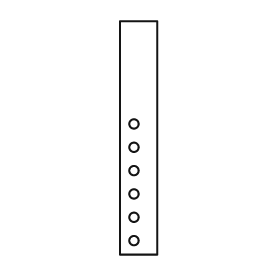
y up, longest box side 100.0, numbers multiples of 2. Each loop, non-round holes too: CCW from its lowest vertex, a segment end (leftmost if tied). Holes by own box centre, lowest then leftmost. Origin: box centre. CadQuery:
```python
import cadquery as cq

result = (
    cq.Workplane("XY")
    .moveTo(-8.0, -50.0)
    .lineTo(8.0, -50.0)
    .lineTo(8.0, 50.0)
    .lineTo(-8.0, 50.0)
    .close()
    .moveTo(-2.0, -44.0)
    .circle(2.0)
    .moveTo(-2.0, -34.0)
    .circle(2.0)
    .moveTo(-2.0, -24.0)
    .circle(2.0)
    .moveTo(-2.0, -14.0)
    .circle(2.0)
    .moveTo(-2.0, -4.0)
    .circle(2.0)
    .moveTo(-2.0, 6.0)
    .circle(2.0)
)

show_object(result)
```